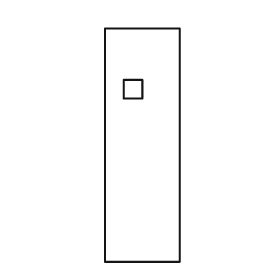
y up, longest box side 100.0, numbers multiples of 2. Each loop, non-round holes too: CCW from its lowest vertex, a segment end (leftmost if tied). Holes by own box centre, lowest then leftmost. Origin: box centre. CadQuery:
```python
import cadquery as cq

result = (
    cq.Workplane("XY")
    .moveTo(-16.0, -50.0)
    .lineTo(16.0, -50.0)
    .lineTo(16.0, 50.0)
    .lineTo(-16.0, 50.0)
    .close()
    .moveTo(-8.0, 20.0)
    .lineTo(0.0, 20.0)
    .lineTo(0.0, 28.0)
    .lineTo(-8.0, 28.0)
    .close()
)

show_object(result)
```